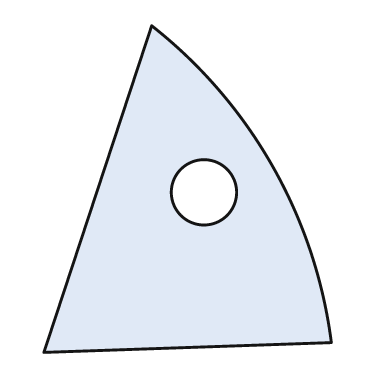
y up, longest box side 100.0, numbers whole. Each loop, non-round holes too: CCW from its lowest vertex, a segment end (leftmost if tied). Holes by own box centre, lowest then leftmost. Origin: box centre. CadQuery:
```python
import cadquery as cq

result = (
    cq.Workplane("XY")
    .moveTo(-44.0, -50.0)
    .lineTo(44.0, -47.0)
    .threePointArc((26.0, 7.0), (-11.0, 50.0))
    .close()
    .moveTo(5.0, -1.0)
    .circle(10.0)
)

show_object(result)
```